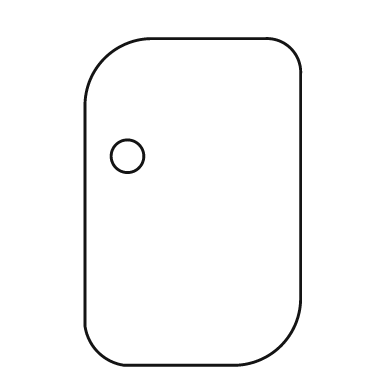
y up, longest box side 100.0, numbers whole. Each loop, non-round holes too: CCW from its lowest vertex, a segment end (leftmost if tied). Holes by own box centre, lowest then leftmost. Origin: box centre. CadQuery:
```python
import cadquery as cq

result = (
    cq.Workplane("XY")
    .moveTo(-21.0, -50.0)
    .lineTo(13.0, -50.0)
    .threePointArc((27.0, -44.0), (33.0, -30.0))
    .lineTo(33.0, 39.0)
    .threePointArc((30.0, 47.0), (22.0, 50.0))
    .lineTo(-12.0, 50.0)
    .threePointArc((-27.0, 44.0), (-33.0, 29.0))
    .lineTo(-33.0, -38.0)
    .threePointArc((-29.0, -46.0), (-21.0, -50.0))
    .close()
    .moveTo(-20.0, 14.0)
    .circle(5.0)
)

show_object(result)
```